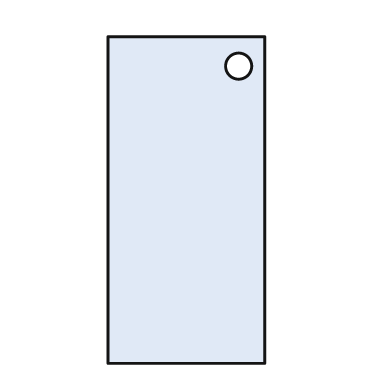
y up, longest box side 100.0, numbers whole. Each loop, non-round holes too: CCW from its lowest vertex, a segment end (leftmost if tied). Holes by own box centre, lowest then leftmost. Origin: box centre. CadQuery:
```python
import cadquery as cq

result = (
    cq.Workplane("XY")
    .moveTo(-24.0, -50.0)
    .lineTo(24.0, -50.0)
    .lineTo(24.0, 50.0)
    .lineTo(-24.0, 50.0)
    .close()
    .moveTo(16.0, 41.0)
    .circle(4.0)
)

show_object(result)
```